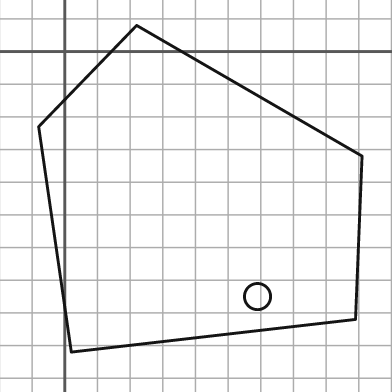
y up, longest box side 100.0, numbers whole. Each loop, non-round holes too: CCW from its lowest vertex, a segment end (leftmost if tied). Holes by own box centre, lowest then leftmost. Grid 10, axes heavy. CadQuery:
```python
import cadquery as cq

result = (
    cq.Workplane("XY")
    .moveTo(2.0, -92.0)
    .lineTo(89.0, -82.0)
    .lineTo(91.0, -32.0)
    .lineTo(22.0, 8.0)
    .lineTo(-8.0, -23.0)
    .close()
    .moveTo(59.0, -75.0)
    .circle(4.0)
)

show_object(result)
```